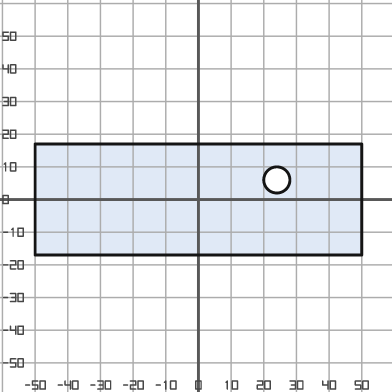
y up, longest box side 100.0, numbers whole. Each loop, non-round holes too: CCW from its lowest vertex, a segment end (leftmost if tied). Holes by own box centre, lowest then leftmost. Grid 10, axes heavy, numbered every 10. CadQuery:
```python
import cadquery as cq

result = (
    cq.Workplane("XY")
    .moveTo(-50.0, -17.0)
    .lineTo(50.0, -17.0)
    .lineTo(50.0, 17.0)
    .lineTo(-50.0, 17.0)
    .close()
    .moveTo(24.0, 6.0)
    .circle(4.0)
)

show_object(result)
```